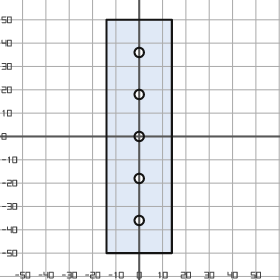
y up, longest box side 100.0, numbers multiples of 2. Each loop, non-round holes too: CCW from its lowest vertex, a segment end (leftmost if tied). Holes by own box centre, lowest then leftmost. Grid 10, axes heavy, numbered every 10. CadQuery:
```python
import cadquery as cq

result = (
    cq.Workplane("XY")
    .moveTo(-14.0, -50.0)
    .lineTo(14.0, -50.0)
    .lineTo(14.0, 50.0)
    .lineTo(-14.0, 50.0)
    .close()
    .moveTo(0.0, -36.0)
    .circle(2.0)
    .moveTo(0.0, -18.0)
    .circle(2.0)
    .moveTo(0.0, 0.0)
    .circle(2.0)
    .moveTo(0.0, 18.0)
    .circle(2.0)
    .moveTo(0.0, 36.0)
    .circle(2.0)
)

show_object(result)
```